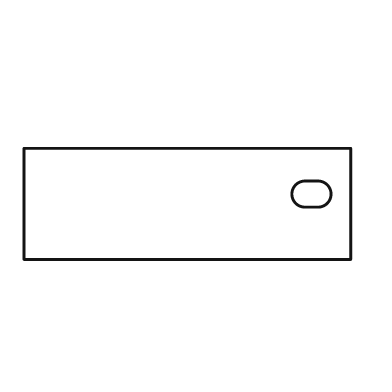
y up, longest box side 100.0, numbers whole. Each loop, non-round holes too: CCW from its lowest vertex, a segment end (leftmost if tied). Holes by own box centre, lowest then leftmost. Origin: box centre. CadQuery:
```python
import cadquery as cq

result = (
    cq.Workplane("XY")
    .moveTo(-50.0, -17.0)
    .lineTo(50.0, -17.0)
    .lineTo(50.0, 17.0)
    .lineTo(-50.0, 17.0)
    .close()
    .moveTo(36.0, -1.0)
    .lineTo(40.0, -1.0)
    .threePointArc((44.0, 3.0), (40.0, 7.0))
    .lineTo(36.0, 7.0)
    .threePointArc((32.0, 3.0), (36.0, -1.0))
    .close()
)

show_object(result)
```